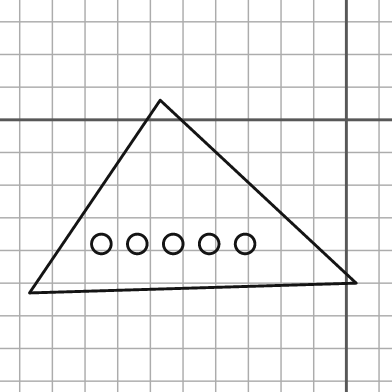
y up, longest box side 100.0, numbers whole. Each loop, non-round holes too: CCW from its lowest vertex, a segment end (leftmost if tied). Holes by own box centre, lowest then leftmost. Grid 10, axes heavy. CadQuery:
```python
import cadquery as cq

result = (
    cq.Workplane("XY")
    .moveTo(-97.0, -53.0)
    .lineTo(3.0, -50.0)
    .lineTo(-57.0, 6.0)
    .close()
    .moveTo(-75.0, -38.0)
    .circle(3.0)
    .moveTo(-64.0, -38.0)
    .circle(3.0)
    .moveTo(-53.0, -38.0)
    .circle(3.0)
    .moveTo(-42.0, -38.0)
    .circle(3.0)
    .moveTo(-31.0, -38.0)
    .circle(3.0)
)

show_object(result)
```